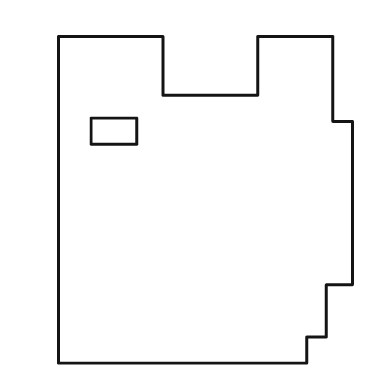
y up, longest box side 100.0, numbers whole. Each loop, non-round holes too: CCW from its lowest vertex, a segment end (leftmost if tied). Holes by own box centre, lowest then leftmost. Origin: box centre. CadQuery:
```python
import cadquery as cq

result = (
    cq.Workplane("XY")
    .moveTo(-45.0, -50.0)
    .lineTo(31.0, -50.0)
    .lineTo(31.0, -42.0)
    .lineTo(37.0, -42.0)
    .lineTo(37.0, -26.0)
    .lineTo(45.0, -26.0)
    .lineTo(45.0, 24.0)
    .lineTo(39.0, 24.0)
    .lineTo(39.0, 50.0)
    .lineTo(16.0, 50.0)
    .lineTo(16.0, 32.0)
    .lineTo(-13.0, 32.0)
    .lineTo(-13.0, 50.0)
    .lineTo(-45.0, 50.0)
    .close()
    .moveTo(-35.0, 17.0)
    .lineTo(-21.0, 17.0)
    .lineTo(-21.0, 25.0)
    .lineTo(-35.0, 25.0)
    .close()
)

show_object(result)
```